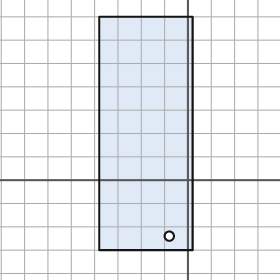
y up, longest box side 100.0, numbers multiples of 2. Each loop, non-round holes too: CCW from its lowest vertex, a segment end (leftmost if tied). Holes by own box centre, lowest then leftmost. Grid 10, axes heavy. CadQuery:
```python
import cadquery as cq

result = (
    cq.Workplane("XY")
    .moveTo(-38.0, -30.0)
    .lineTo(2.0, -30.0)
    .lineTo(2.0, 70.0)
    .lineTo(-38.0, 70.0)
    .close()
    .moveTo(-8.0, -24.0)
    .circle(2.0)
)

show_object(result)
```